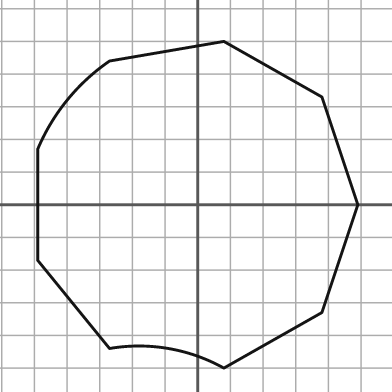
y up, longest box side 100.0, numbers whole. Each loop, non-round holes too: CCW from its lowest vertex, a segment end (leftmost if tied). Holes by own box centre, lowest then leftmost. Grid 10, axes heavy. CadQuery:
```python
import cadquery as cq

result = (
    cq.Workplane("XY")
    .moveTo(8.0, -50.0)
    .lineTo(38.0, -33.0)
    .lineTo(49.0, 0.0)
    .lineTo(38.0, 33.0)
    .lineTo(8.0, 50.0)
    .lineTo(-27.0, 44.0)
    .threePointArc((-40.0, 32.0), (-49.0, 17.0))
    .lineTo(-49.0, -17.0)
    .lineTo(-27.0, -44.0)
    .threePointArc((-9.0, -44.0), (8.0, -50.0))
    .close()
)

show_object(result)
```